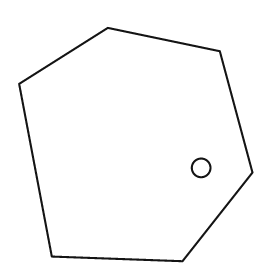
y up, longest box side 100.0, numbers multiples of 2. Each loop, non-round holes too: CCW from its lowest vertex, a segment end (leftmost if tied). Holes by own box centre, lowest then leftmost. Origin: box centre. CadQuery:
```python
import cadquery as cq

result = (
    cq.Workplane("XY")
    .moveTo(20.0, -50.0)
    .lineTo(50.0, -12.0)
    .lineTo(36.0, 40.0)
    .lineTo(-12.0, 50.0)
    .lineTo(-50.0, 26.0)
    .lineTo(-36.0, -48.0)
    .close()
    .moveTo(28.0, -10.0)
    .circle(4.0)
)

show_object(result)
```